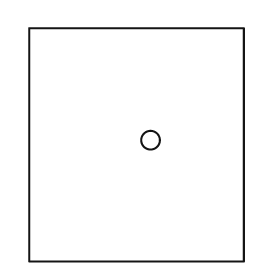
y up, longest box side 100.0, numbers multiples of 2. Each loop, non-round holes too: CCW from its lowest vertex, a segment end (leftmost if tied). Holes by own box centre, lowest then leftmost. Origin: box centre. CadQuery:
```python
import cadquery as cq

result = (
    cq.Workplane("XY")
    .moveTo(-46.0, -50.0)
    .lineTo(46.0, -50.0)
    .lineTo(46.0, 50.0)
    .lineTo(-46.0, 50.0)
    .close()
    .moveTo(6.0, 2.0)
    .circle(4.0)
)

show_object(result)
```